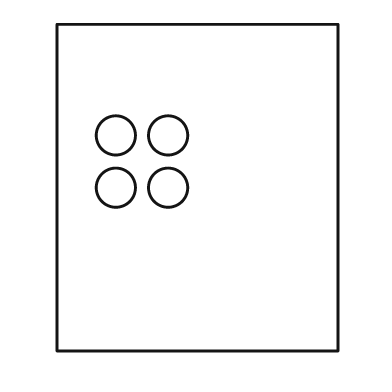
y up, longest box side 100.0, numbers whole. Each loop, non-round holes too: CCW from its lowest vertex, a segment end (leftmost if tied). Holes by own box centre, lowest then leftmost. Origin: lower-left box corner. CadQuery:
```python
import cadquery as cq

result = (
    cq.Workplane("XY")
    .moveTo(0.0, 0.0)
    .lineTo(86.0, 0.0)
    .lineTo(86.0, 100.0)
    .lineTo(0.0, 100.0)
    .close()
    .moveTo(18.0, 50.0)
    .circle(6.0)
    .moveTo(34.0, 50.0)
    .circle(6.0)
    .moveTo(18.0, 66.0)
    .circle(6.0)
    .moveTo(34.0, 66.0)
    .circle(6.0)
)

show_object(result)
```